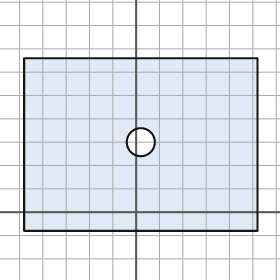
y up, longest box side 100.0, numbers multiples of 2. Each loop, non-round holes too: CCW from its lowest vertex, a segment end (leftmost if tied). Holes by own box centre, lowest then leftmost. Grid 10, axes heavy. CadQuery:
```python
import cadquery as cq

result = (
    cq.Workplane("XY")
    .moveTo(-48.0, -8.0)
    .lineTo(52.0, -8.0)
    .lineTo(52.0, 66.0)
    .lineTo(-48.0, 66.0)
    .close()
    .moveTo(2.0, 30.0)
    .circle(6.0)
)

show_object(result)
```